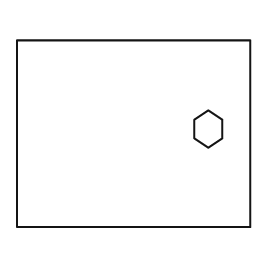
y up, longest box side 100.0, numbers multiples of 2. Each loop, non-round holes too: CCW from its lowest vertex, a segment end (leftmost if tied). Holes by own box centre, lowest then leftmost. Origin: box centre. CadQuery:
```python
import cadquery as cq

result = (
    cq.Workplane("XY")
    .moveTo(-50.0, -40.0)
    .lineTo(50.0, -40.0)
    .lineTo(50.0, 40.0)
    .lineTo(-50.0, 40.0)
    .close()
    .moveTo(32.0, -6.0)
    .lineTo(38.0, -2.0)
    .lineTo(38.0, 6.0)
    .lineTo(32.0, 10.0)
    .lineTo(26.0, 6.0)
    .lineTo(26.0, -2.0)
    .close()
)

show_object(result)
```